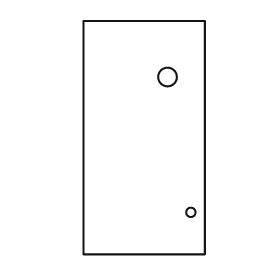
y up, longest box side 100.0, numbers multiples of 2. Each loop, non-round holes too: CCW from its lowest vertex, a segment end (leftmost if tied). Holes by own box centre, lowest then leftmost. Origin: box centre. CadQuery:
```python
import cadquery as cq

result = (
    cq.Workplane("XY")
    .moveTo(-26.0, -50.0)
    .lineTo(26.0, -50.0)
    .lineTo(26.0, 50.0)
    .lineTo(-26.0, 50.0)
    .close()
    .moveTo(20.0, -32.0)
    .circle(2.0)
    .moveTo(10.0, 26.0)
    .circle(4.0)
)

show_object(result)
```